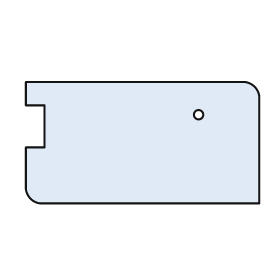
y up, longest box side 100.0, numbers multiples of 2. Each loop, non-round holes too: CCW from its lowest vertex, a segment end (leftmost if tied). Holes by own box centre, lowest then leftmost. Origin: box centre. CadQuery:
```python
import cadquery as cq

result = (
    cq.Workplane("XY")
    .moveTo(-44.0, -26.0)
    .lineTo(50.0, -26.0)
    .lineTo(50.0, 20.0)
    .threePointArc((48.0, 24.0), (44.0, 26.0))
    .lineTo(-50.0, 26.0)
    .lineTo(-50.0, 16.0)
    .lineTo(-42.0, 16.0)
    .lineTo(-42.0, -2.0)
    .lineTo(-50.0, -2.0)
    .lineTo(-50.0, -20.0)
    .threePointArc((-48.0, -24.0), (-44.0, -26.0))
    .close()
    .moveTo(24.0, 12.0)
    .circle(2.0)
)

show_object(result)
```